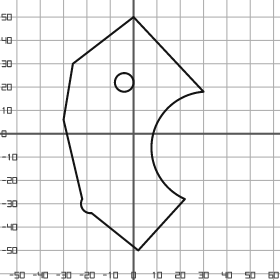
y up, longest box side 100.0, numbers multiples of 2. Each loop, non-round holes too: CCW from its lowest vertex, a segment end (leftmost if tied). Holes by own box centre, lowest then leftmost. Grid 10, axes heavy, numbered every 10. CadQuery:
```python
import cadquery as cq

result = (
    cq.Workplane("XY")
    .moveTo(2.0, -50.0)
    .lineTo(22.0, -28.0)
    .threePointArc((8.0, -2.0), (30.0, 18.0))
    .lineTo(0.0, 50.0)
    .lineTo(-26.0, 30.0)
    .lineTo(-30.0, 6.0)
    .lineTo(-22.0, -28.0)
    .threePointArc((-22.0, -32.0), (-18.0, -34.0))
    .close()
    .moveTo(-4.0, 22.0)
    .circle(4.0)
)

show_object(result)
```